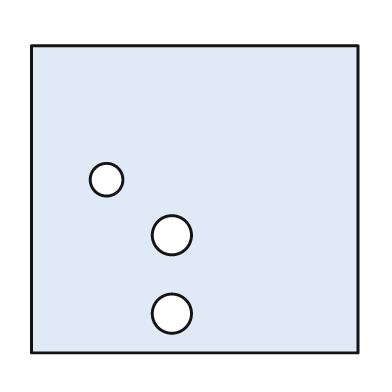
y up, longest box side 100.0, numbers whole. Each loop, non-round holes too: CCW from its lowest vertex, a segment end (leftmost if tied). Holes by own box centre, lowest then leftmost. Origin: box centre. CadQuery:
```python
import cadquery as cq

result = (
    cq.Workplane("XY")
    .moveTo(-50.0, -47.0)
    .lineTo(50.0, -47.0)
    .lineTo(50.0, 47.0)
    .lineTo(-50.0, 47.0)
    .close()
    .moveTo(-7.0, -35.0)
    .circle(6.0)
    .moveTo(-7.0, -11.0)
    .circle(6.0)
    .moveTo(-27.0, 6.0)
    .circle(5.0)
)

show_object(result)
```